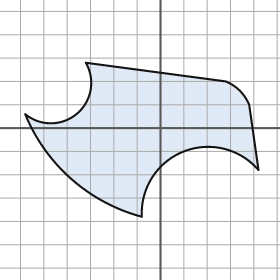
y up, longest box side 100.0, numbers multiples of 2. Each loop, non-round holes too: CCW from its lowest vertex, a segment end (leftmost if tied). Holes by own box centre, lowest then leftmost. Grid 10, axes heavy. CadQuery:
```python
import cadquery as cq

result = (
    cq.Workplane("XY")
    .moveTo(-8.0, -38.0)
    .threePointArc((10.0, -10.0), (42.0, -18.0))
    .lineTo(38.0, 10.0)
    .threePointArc((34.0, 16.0), (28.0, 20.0))
    .lineTo(-32.0, 28.0)
    .threePointArc((-36.0, 6.0), (-58.0, 6.0))
    .threePointArc((-38.0, -22.0), (-8.0, -38.0))
    .close()
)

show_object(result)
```